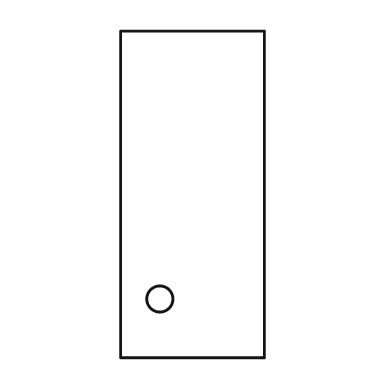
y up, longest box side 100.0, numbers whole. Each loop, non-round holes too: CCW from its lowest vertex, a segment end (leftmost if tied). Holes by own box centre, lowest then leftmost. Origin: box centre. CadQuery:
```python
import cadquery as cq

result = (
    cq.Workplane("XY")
    .moveTo(-22.0, -50.0)
    .lineTo(22.0, -50.0)
    .lineTo(22.0, 50.0)
    .lineTo(-22.0, 50.0)
    .close()
    .moveTo(-10.0, -32.0)
    .circle(4.0)
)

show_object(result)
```